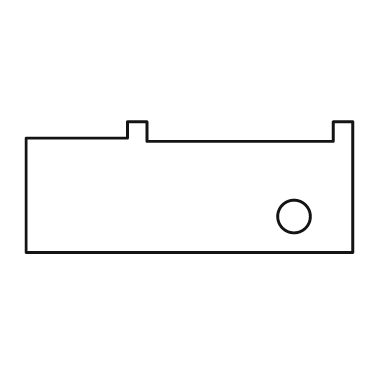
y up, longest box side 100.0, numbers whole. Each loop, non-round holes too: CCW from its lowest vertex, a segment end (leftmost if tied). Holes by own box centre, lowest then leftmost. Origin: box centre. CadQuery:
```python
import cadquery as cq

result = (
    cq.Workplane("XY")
    .moveTo(-50.0, -20.0)
    .lineTo(50.0, -20.0)
    .lineTo(50.0, 20.0)
    .lineTo(44.0, 20.0)
    .lineTo(44.0, 14.0)
    .lineTo(-13.0, 14.0)
    .lineTo(-13.0, 20.0)
    .lineTo(-19.0, 20.0)
    .lineTo(-19.0, 15.0)
    .lineTo(-50.0, 15.0)
    .close()
    .moveTo(32.0, -9.0)
    .circle(5.0)
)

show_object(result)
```